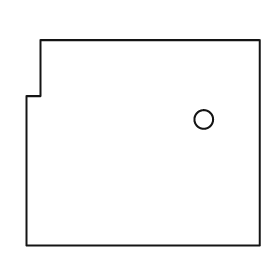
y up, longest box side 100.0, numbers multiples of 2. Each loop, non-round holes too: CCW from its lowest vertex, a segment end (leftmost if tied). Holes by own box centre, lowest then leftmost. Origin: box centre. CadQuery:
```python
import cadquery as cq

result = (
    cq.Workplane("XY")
    .moveTo(-50.0, -44.0)
    .lineTo(50.0, -44.0)
    .lineTo(50.0, 44.0)
    .lineTo(-44.0, 44.0)
    .lineTo(-44.0, 20.0)
    .lineTo(-50.0, 20.0)
    .close()
    .moveTo(26.0, 10.0)
    .circle(4.0)
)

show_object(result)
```